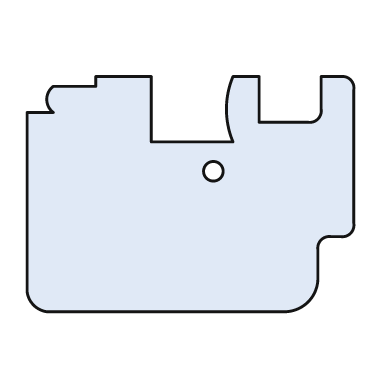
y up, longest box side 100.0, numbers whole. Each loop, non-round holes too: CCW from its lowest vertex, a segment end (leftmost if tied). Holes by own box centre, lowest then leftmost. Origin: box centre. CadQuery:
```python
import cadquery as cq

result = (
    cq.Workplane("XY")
    .moveTo(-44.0, -36.0)
    .lineTo(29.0, -36.0)
    .threePointArc((36.0, -33.0), (39.0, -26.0))
    .lineTo(39.0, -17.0)
    .threePointArc((40.0, -14.0), (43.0, -13.0))
    .lineTo(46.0, -13.0)
    .threePointArc((49.0, -12.0), (50.0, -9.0))
    .lineTo(50.0, 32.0)
    .threePointArc((49.0, 35.0), (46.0, 36.0))
    .lineTo(40.0, 36.0)
    .lineTo(40.0, 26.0)
    .threePointArc((39.0, 23.0), (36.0, 22.0))
    .lineTo(21.0, 22.0)
    .lineTo(21.0, 36.0)
    .lineTo(13.0, 36.0)
    .threePointArc((11.0, 26.0), (13.0, 16.0))
    .lineTo(-12.0, 16.0)
    .lineTo(-12.0, 36.0)
    .lineTo(-29.0, 36.0)
    .lineTo(-29.0, 33.0)
    .lineTo(-42.0, 33.0)
    .threePointArc((-44.0, 29.0), (-42.0, 25.0))
    .lineTo(-50.0, 25.0)
    .lineTo(-50.0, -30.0)
    .threePointArc((-48.0, -34.0), (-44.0, -36.0))
    .close()
    .moveTo(7.0, 7.0)
    .circle(3.0)
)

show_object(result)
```